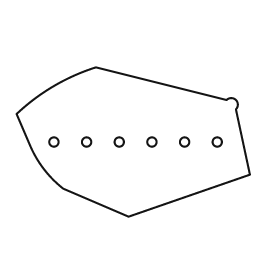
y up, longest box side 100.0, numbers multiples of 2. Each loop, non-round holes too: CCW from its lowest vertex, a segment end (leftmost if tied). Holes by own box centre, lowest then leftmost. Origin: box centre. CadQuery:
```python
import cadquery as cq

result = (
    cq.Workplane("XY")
    .moveTo(-2.0, -32.0)
    .lineTo(50.0, -14.0)
    .lineTo(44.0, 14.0)
    .threePointArc((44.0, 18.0), (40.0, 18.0))
    .lineTo(-16.0, 32.0)
    .threePointArc((-34.0, 24.0), (-50.0, 12.0))
    .lineTo(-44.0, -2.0)
    .threePointArc((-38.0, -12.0), (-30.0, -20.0))
    .close()
    .moveTo(-34.0, 0.0)
    .circle(2.0)
    .moveTo(-20.0, 0.0)
    .circle(2.0)
    .moveTo(-6.0, 0.0)
    .circle(2.0)
    .moveTo(8.0, 0.0)
    .circle(2.0)
    .moveTo(22.0, 0.0)
    .circle(2.0)
    .moveTo(36.0, 0.0)
    .circle(2.0)
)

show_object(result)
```